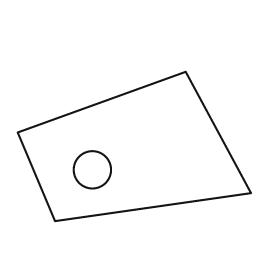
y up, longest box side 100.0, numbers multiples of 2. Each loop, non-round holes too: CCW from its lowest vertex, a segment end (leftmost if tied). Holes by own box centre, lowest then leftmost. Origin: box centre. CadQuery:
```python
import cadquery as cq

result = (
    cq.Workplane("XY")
    .moveTo(-34.0, -32.0)
    .lineTo(50.0, -20.0)
    .lineTo(22.0, 32.0)
    .lineTo(-50.0, 6.0)
    .close()
    .moveTo(-18.0, -10.0)
    .circle(8.0)
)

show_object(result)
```